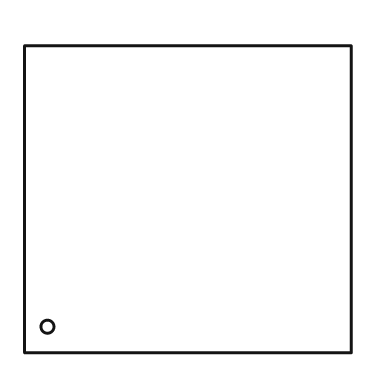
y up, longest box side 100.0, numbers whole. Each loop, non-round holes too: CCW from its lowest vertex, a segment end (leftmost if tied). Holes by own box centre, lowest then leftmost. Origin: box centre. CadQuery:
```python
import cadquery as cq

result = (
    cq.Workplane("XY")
    .moveTo(-50.0, -47.0)
    .lineTo(50.0, -47.0)
    .lineTo(50.0, 47.0)
    .lineTo(-50.0, 47.0)
    .close()
    .moveTo(-43.0, -39.0)
    .circle(2.0)
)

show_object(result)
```